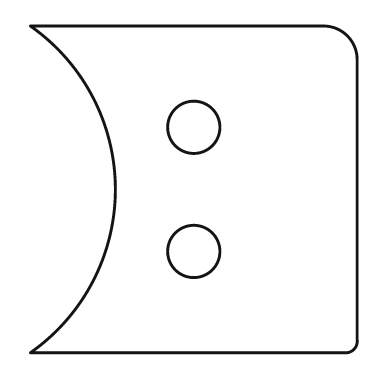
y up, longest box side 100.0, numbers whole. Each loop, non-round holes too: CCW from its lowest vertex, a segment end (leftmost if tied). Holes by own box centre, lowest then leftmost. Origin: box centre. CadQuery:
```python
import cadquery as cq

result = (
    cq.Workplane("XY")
    .moveTo(-50.0, -50.0)
    .lineTo(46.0, -50.0)
    .threePointArc((49.0, -49.0), (50.0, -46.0))
    .lineTo(50.0, 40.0)
    .threePointArc((47.0, 47.0), (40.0, 50.0))
    .lineTo(-50.0, 50.0)
    .threePointArc((-24.0, 0.0), (-50.0, -50.0))
    .close()
    .moveTo(0.0, -19.0)
    .circle(8.0)
    .moveTo(0.0, 19.0)
    .circle(8.0)
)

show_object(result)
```